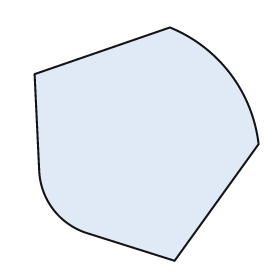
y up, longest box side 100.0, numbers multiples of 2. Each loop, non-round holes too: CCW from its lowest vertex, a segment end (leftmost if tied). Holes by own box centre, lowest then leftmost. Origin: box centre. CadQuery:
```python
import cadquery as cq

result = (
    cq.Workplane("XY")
    .moveTo(12.0, -50.0)
    .lineTo(48.0, 0.0)
    .threePointArc((36.0, 30.0), (10.0, 50.0))
    .lineTo(-48.0, 30.0)
    .lineTo(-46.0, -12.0)
    .threePointArc((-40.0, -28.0), (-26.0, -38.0))
    .close()
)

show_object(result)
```